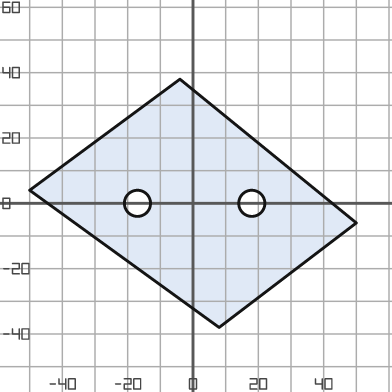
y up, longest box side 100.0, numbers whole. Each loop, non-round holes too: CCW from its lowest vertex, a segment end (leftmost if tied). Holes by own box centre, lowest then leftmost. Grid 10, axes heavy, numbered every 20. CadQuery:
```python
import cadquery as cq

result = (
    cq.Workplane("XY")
    .moveTo(8.0, -38.0)
    .lineTo(50.0, -6.0)
    .lineTo(-4.0, 38.0)
    .lineTo(-50.0, 4.0)
    .close()
    .moveTo(-17.0, 0.0)
    .circle(4.0)
    .moveTo(18.0, 0.0)
    .circle(4.0)
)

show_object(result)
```